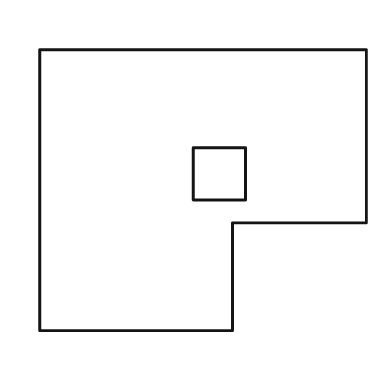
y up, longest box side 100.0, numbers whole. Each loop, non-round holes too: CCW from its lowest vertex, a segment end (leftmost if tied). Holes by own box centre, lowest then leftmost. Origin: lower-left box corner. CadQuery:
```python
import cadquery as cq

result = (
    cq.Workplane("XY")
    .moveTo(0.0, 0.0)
    .lineTo(59.0, 0.0)
    .lineTo(59.0, 33.0)
    .lineTo(100.0, 33.0)
    .lineTo(100.0, 86.0)
    .lineTo(0.0, 86.0)
    .close()
    .moveTo(47.0, 40.0)
    .lineTo(63.0, 40.0)
    .lineTo(63.0, 56.0)
    .lineTo(47.0, 56.0)
    .close()
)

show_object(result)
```